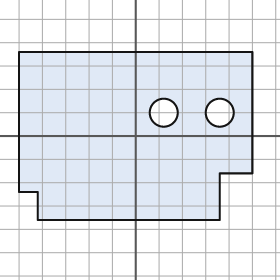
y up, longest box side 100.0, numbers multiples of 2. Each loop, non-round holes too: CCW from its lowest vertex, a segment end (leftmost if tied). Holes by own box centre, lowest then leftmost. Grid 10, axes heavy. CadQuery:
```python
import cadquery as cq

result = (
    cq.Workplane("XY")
    .moveTo(-42.0, -36.0)
    .lineTo(36.0, -36.0)
    .lineTo(36.0, -16.0)
    .lineTo(50.0, -16.0)
    .lineTo(50.0, 36.0)
    .lineTo(-50.0, 36.0)
    .lineTo(-50.0, -24.0)
    .lineTo(-42.0, -24.0)
    .close()
    .moveTo(12.0, 10.0)
    .circle(6.0)
    .moveTo(36.0, 10.0)
    .circle(6.0)
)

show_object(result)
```